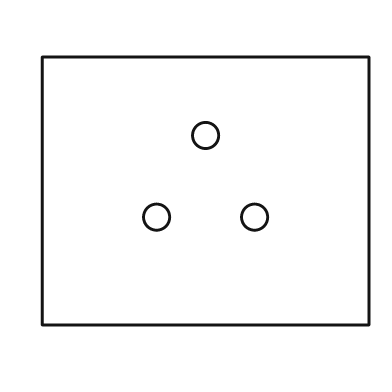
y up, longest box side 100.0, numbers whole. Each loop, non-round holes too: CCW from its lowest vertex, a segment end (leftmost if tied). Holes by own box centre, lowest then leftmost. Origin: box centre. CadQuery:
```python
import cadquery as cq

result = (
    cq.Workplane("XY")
    .moveTo(-50.0, -41.0)
    .lineTo(50.0, -41.0)
    .lineTo(50.0, 41.0)
    .lineTo(-50.0, 41.0)
    .close()
    .moveTo(-15.0, -8.0)
    .circle(4.0)
    .moveTo(15.0, -8.0)
    .circle(4.0)
    .moveTo(0.0, 17.0)
    .circle(4.0)
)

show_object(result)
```